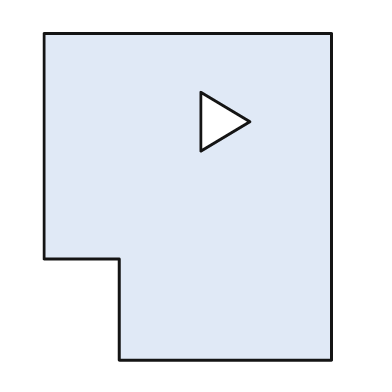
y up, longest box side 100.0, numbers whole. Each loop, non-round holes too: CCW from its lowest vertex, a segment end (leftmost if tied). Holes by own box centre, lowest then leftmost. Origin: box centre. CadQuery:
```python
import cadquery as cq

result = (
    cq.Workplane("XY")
    .moveTo(-21.0, -50.0)
    .lineTo(44.0, -50.0)
    .lineTo(44.0, 50.0)
    .lineTo(-44.0, 50.0)
    .lineTo(-44.0, -19.0)
    .lineTo(-21.0, -19.0)
    .close()
    .moveTo(4.0, 14.0)
    .lineTo(19.0, 23.0)
    .lineTo(4.0, 32.0)
    .close()
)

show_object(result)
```